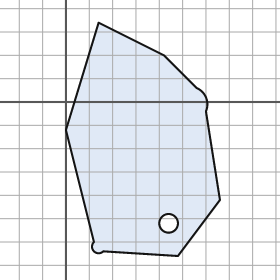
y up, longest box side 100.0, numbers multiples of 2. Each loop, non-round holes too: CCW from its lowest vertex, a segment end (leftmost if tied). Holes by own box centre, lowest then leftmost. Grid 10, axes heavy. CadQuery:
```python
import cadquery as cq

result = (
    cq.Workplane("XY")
    .moveTo(48.0, -66.0)
    .lineTo(66.0, -42.0)
    .lineTo(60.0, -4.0)
    .threePointArc((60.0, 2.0), (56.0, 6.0))
    .lineTo(42.0, 20.0)
    .lineTo(14.0, 34.0)
    .lineTo(0.0, -12.0)
    .lineTo(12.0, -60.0)
    .threePointArc((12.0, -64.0), (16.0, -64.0))
    .close()
    .moveTo(44.0, -52.0)
    .circle(4.0)
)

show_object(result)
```